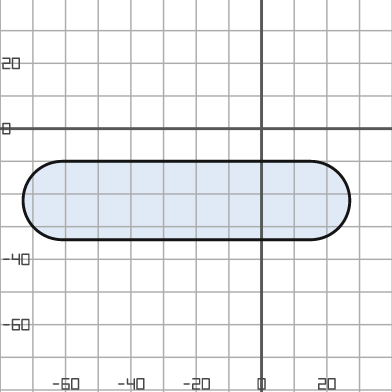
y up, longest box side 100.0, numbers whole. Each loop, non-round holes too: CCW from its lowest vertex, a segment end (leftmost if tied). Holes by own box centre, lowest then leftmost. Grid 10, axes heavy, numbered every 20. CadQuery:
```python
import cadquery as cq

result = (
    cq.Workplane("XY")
    .moveTo(-61.0, -34.0)
    .lineTo(15.0, -34.0)
    .threePointArc((27.0, -22.0), (15.0, -10.0))
    .lineTo(-61.0, -10.0)
    .threePointArc((-73.0, -22.0), (-61.0, -34.0))
    .close()
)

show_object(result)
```